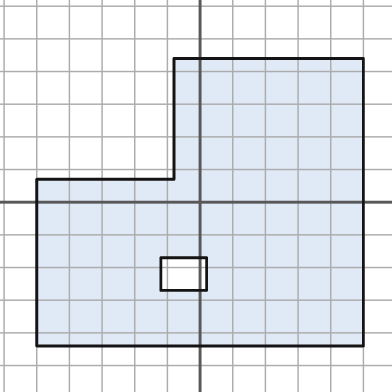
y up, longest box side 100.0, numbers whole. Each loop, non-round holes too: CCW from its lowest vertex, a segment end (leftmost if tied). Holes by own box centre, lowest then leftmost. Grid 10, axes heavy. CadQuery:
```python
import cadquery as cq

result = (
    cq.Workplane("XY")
    .moveTo(-50.0, -44.0)
    .lineTo(50.0, -44.0)
    .lineTo(50.0, 44.0)
    .lineTo(-8.0, 44.0)
    .lineTo(-8.0, 7.0)
    .lineTo(-50.0, 7.0)
    .close()
    .moveTo(-12.0, -27.0)
    .lineTo(2.0, -27.0)
    .lineTo(2.0, -17.0)
    .lineTo(-12.0, -17.0)
    .close()
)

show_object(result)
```